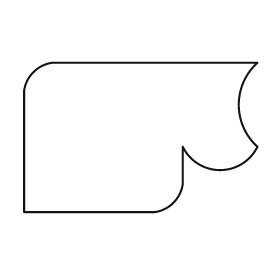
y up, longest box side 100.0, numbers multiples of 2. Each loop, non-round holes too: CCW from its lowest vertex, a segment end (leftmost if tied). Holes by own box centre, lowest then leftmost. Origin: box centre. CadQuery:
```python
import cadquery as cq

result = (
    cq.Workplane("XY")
    .moveTo(-50.0, -32.0)
    .lineTo(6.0, -32.0)
    .threePointArc((14.0, -28.0), (18.0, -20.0))
    .lineTo(18.0, -4.0)
    .threePointArc((34.0, -14.0), (50.0, -4.0))
    .threePointArc((42.0, 14.0), (50.0, 32.0))
    .lineTo(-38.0, 32.0)
    .threePointArc((-46.0, 28.0), (-50.0, 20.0))
    .close()
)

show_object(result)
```